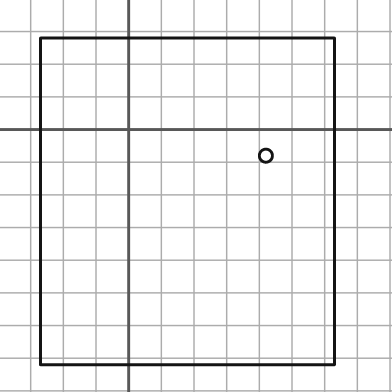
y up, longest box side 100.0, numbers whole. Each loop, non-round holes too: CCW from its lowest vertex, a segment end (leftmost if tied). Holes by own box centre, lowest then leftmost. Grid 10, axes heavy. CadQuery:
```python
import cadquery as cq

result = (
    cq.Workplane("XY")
    .moveTo(-27.0, -72.0)
    .lineTo(63.0, -72.0)
    .lineTo(63.0, 28.0)
    .lineTo(-27.0, 28.0)
    .close()
    .moveTo(42.0, -8.0)
    .circle(2.0)
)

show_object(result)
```